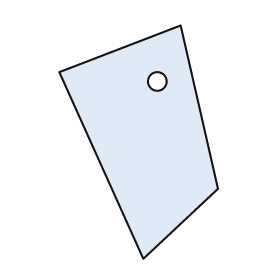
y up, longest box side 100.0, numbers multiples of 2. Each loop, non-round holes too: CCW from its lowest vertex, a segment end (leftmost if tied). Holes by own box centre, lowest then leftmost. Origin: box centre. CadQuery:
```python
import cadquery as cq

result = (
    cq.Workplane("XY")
    .moveTo(2.0, -50.0)
    .lineTo(34.0, -20.0)
    .lineTo(18.0, 50.0)
    .lineTo(-34.0, 30.0)
    .close()
    .moveTo(8.0, 26.0)
    .circle(4.0)
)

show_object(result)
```